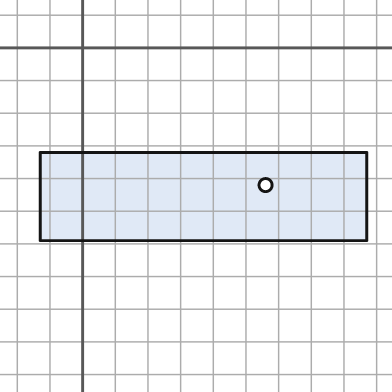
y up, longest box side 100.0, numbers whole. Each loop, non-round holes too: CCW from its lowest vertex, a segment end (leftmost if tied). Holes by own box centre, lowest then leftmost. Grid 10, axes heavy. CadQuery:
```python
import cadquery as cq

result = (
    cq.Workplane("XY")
    .moveTo(-13.0, -59.0)
    .lineTo(87.0, -59.0)
    .lineTo(87.0, -32.0)
    .lineTo(-13.0, -32.0)
    .close()
    .moveTo(56.0, -42.0)
    .circle(2.0)
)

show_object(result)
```